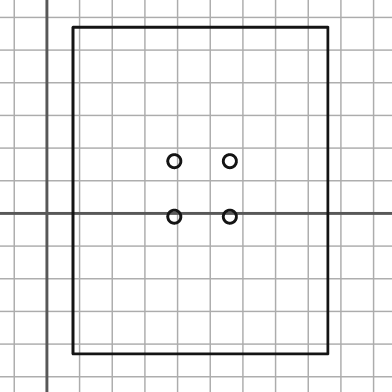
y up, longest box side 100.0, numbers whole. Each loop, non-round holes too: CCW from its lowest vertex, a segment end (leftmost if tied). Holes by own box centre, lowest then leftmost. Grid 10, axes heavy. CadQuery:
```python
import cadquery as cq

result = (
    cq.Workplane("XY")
    .moveTo(8.0, -43.0)
    .lineTo(86.0, -43.0)
    .lineTo(86.0, 57.0)
    .lineTo(8.0, 57.0)
    .close()
    .moveTo(39.0, -1.0)
    .circle(2.0)
    .moveTo(56.0, -1.0)
    .circle(2.0)
    .moveTo(39.0, 16.0)
    .circle(2.0)
    .moveTo(56.0, 16.0)
    .circle(2.0)
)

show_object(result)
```